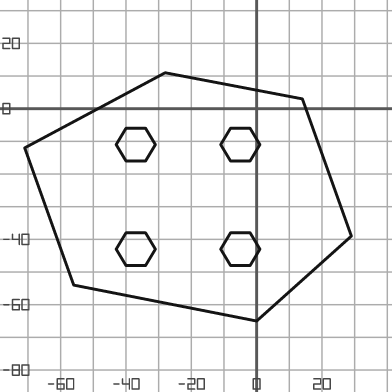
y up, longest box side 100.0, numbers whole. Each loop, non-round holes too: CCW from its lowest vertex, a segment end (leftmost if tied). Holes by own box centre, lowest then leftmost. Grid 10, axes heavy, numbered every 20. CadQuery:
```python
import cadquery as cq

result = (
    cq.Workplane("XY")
    .moveTo(0.0, -65.0)
    .lineTo(29.0, -39.0)
    .lineTo(14.0, 3.0)
    .lineTo(-28.0, 11.0)
    .lineTo(-71.0, -12.0)
    .lineTo(-56.0, -54.0)
    .close()
    .moveTo(-40.0, -48.0)
    .lineTo(-34.0, -48.0)
    .lineTo(-31.0, -43.0)
    .lineTo(-34.0, -38.0)
    .lineTo(-40.0, -38.0)
    .lineTo(-43.0, -43.0)
    .close()
    .moveTo(-8.0, -48.0)
    .lineTo(-2.0, -48.0)
    .lineTo(1.0, -43.0)
    .lineTo(-2.0, -38.0)
    .lineTo(-8.0, -38.0)
    .lineTo(-11.0, -43.0)
    .close()
    .moveTo(-40.0, -16.0)
    .lineTo(-34.0, -16.0)
    .lineTo(-31.0, -11.0)
    .lineTo(-34.0, -6.0)
    .lineTo(-40.0, -6.0)
    .lineTo(-43.0, -11.0)
    .close()
    .moveTo(-8.0, -16.0)
    .lineTo(-2.0, -16.0)
    .lineTo(1.0, -11.0)
    .lineTo(-2.0, -6.0)
    .lineTo(-8.0, -6.0)
    .lineTo(-11.0, -11.0)
    .close()
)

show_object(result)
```